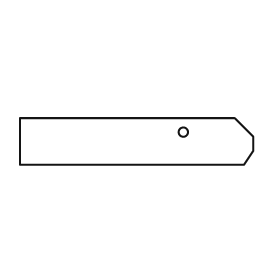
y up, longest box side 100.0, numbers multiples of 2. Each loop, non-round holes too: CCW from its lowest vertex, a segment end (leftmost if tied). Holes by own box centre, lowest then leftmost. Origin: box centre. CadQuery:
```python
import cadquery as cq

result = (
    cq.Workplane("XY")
    .moveTo(-50.0, -10.0)
    .lineTo(46.0, -10.0)
    .lineTo(50.0, -4.0)
    .lineTo(50.0, 2.0)
    .lineTo(42.0, 10.0)
    .lineTo(-50.0, 10.0)
    .close()
    .moveTo(20.0, 4.0)
    .circle(2.0)
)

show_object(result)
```